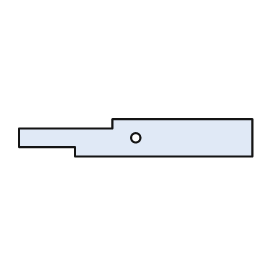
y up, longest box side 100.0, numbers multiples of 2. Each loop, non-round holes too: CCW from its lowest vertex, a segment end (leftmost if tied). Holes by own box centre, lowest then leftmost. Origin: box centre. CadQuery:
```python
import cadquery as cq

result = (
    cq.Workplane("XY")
    .moveTo(-26.0, -8.0)
    .lineTo(50.0, -8.0)
    .lineTo(50.0, 8.0)
    .lineTo(-10.0, 8.0)
    .lineTo(-10.0, 4.0)
    .lineTo(-50.0, 4.0)
    .lineTo(-50.0, -4.0)
    .lineTo(-26.0, -4.0)
    .close()
    .moveTo(0.0, 0.0)
    .circle(2.0)
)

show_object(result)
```